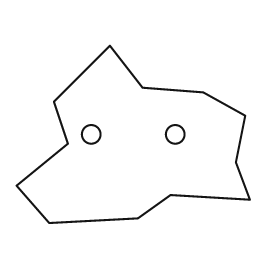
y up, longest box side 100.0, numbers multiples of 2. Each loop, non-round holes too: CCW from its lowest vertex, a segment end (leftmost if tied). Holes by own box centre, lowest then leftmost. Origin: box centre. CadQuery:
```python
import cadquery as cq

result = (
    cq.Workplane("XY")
    .moveTo(-36.0, -38.0)
    .lineTo(2.0, -36.0)
    .lineTo(16.0, -26.0)
    .lineTo(50.0, -28.0)
    .lineTo(44.0, -12.0)
    .lineTo(48.0, 8.0)
    .lineTo(30.0, 18.0)
    .lineTo(4.0, 20.0)
    .lineTo(-10.0, 38.0)
    .lineTo(-34.0, 14.0)
    .lineTo(-28.0, -4.0)
    .lineTo(-50.0, -22.0)
    .close()
    .moveTo(-18.0, 0.0)
    .circle(4.0)
    .moveTo(18.0, 0.0)
    .circle(4.0)
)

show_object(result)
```